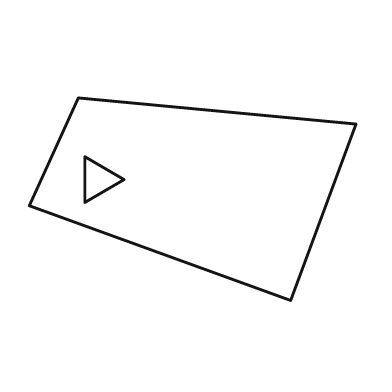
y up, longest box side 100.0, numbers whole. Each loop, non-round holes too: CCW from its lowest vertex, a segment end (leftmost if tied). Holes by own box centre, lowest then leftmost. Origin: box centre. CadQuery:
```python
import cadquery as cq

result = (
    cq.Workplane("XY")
    .moveTo(30.0, -31.0)
    .lineTo(50.0, 23.0)
    .lineTo(-35.0, 31.0)
    .lineTo(-50.0, -2.0)
    .close()
    .moveTo(-33.0, -1.0)
    .lineTo(-21.0, 6.0)
    .lineTo(-33.0, 13.0)
    .close()
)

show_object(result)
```